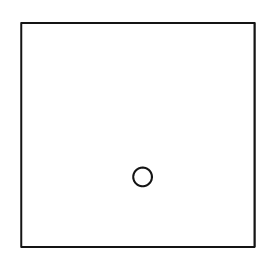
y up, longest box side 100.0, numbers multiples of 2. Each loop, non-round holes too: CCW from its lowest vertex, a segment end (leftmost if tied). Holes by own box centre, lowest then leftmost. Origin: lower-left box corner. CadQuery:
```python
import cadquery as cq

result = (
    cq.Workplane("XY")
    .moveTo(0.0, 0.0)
    .lineTo(100.0, 0.0)
    .lineTo(100.0, 96.0)
    .lineTo(0.0, 96.0)
    .close()
    .moveTo(52.0, 30.0)
    .circle(4.0)
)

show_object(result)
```